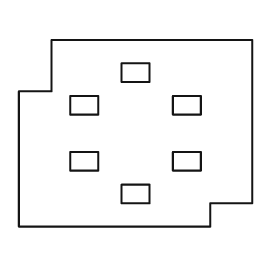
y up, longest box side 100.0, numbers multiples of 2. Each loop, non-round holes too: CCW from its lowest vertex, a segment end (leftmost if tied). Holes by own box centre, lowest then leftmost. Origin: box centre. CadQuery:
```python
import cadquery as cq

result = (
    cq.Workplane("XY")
    .moveTo(-50.0, -40.0)
    .lineTo(32.0, -40.0)
    .lineTo(32.0, -30.0)
    .lineTo(50.0, -30.0)
    .lineTo(50.0, 40.0)
    .lineTo(-36.0, 40.0)
    .lineTo(-36.0, 18.0)
    .lineTo(-50.0, 18.0)
    .close()
    .moveTo(-6.0, -30.0)
    .lineTo(6.0, -30.0)
    .lineTo(6.0, -22.0)
    .lineTo(-6.0, -22.0)
    .close()
    .moveTo(-28.0, -16.0)
    .lineTo(-16.0, -16.0)
    .lineTo(-16.0, -8.0)
    .lineTo(-28.0, -8.0)
    .close()
    .moveTo(16.0, -16.0)
    .lineTo(28.0, -16.0)
    .lineTo(28.0, -8.0)
    .lineTo(16.0, -8.0)
    .close()
    .moveTo(-28.0, 8.0)
    .lineTo(-16.0, 8.0)
    .lineTo(-16.0, 16.0)
    .lineTo(-28.0, 16.0)
    .close()
    .moveTo(16.0, 8.0)
    .lineTo(28.0, 8.0)
    .lineTo(28.0, 16.0)
    .lineTo(16.0, 16.0)
    .close()
    .moveTo(-6.0, 22.0)
    .lineTo(6.0, 22.0)
    .lineTo(6.0, 30.0)
    .lineTo(-6.0, 30.0)
    .close()
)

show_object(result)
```